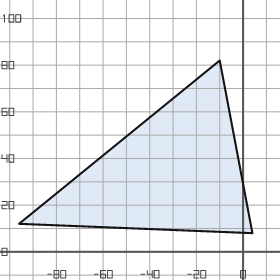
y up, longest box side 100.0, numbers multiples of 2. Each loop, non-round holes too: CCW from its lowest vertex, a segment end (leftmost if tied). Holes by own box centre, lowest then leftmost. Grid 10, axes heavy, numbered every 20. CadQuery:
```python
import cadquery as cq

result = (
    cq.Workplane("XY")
    .moveTo(4.0, 8.0)
    .lineTo(-10.0, 82.0)
    .lineTo(-96.0, 12.0)
    .close()
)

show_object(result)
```